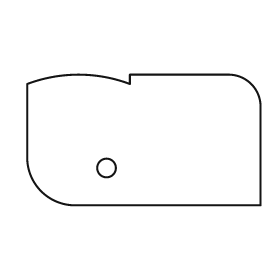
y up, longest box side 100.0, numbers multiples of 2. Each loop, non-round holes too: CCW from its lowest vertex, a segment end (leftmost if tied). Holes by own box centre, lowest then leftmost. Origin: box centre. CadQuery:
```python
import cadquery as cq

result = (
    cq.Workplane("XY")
    .moveTo(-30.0, -28.0)
    .lineTo(50.0, -28.0)
    .lineTo(50.0, 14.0)
    .threePointArc((46.0, 24.0), (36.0, 28.0))
    .lineTo(-6.0, 28.0)
    .lineTo(-6.0, 24.0)
    .threePointArc((-28.0, 28.0), (-50.0, 24.0))
    .lineTo(-50.0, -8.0)
    .threePointArc((-44.0, -22.0), (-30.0, -28.0))
    .close()
    .moveTo(-16.0, -12.0)
    .circle(4.0)
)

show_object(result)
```